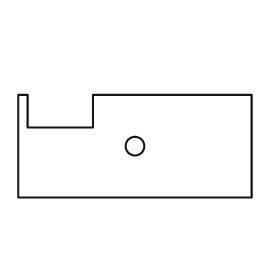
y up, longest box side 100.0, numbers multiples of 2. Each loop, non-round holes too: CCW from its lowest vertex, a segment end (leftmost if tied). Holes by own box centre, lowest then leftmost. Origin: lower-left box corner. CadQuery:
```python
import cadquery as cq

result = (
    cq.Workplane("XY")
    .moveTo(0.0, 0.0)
    .lineTo(100.0, 0.0)
    .lineTo(100.0, 44.0)
    .lineTo(32.0, 44.0)
    .lineTo(32.0, 30.0)
    .lineTo(4.0, 30.0)
    .lineTo(4.0, 44.0)
    .lineTo(0.0, 44.0)
    .close()
    .moveTo(50.0, 22.0)
    .circle(4.0)
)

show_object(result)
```